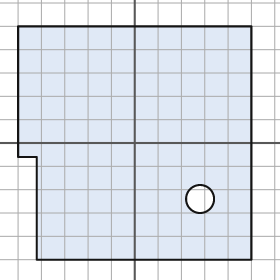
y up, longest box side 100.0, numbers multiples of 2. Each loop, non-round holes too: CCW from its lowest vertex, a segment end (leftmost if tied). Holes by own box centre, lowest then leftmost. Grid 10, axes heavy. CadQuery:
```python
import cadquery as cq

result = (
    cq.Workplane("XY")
    .moveTo(-42.0, -50.0)
    .lineTo(50.0, -50.0)
    .lineTo(50.0, 50.0)
    .lineTo(-50.0, 50.0)
    .lineTo(-50.0, -6.0)
    .lineTo(-42.0, -6.0)
    .close()
    .moveTo(28.0, -24.0)
    .circle(6.0)
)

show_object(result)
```